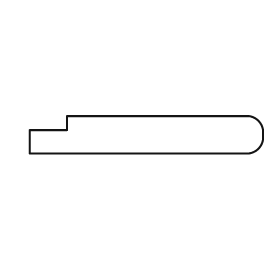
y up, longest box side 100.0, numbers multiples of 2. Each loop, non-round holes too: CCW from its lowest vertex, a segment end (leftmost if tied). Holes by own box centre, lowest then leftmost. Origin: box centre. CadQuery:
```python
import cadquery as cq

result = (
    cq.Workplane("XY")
    .moveTo(-50.0, -8.0)
    .lineTo(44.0, -8.0)
    .threePointArc((48.0, -6.0), (50.0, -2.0))
    .lineTo(50.0, 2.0)
    .threePointArc((48.0, 6.0), (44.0, 8.0))
    .lineTo(-34.0, 8.0)
    .lineTo(-34.0, 2.0)
    .lineTo(-50.0, 2.0)
    .close()
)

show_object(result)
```